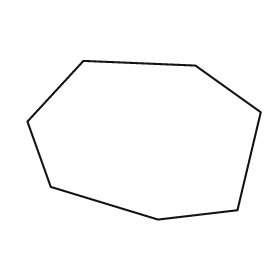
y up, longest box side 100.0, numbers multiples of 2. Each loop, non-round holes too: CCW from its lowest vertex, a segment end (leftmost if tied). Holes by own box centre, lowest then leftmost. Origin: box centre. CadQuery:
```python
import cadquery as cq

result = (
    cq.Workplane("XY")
    .moveTo(6.0, -34.0)
    .lineTo(40.0, -30.0)
    .lineTo(50.0, 12.0)
    .lineTo(22.0, 32.0)
    .lineTo(-26.0, 34.0)
    .lineTo(-50.0, 8.0)
    .lineTo(-40.0, -20.0)
    .close()
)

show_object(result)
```